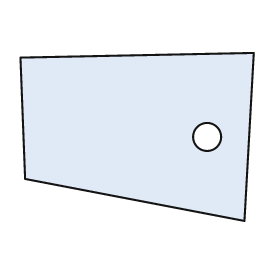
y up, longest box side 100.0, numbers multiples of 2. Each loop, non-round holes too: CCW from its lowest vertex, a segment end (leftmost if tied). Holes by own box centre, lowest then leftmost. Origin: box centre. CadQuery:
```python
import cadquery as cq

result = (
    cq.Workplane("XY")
    .moveTo(46.0, -36.0)
    .lineTo(50.0, 36.0)
    .lineTo(-50.0, 34.0)
    .lineTo(-48.0, -18.0)
    .close()
    .moveTo(30.0, 0.0)
    .circle(6.0)
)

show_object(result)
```